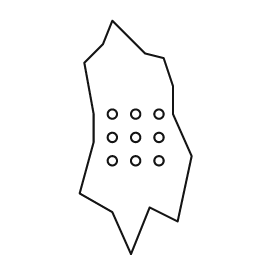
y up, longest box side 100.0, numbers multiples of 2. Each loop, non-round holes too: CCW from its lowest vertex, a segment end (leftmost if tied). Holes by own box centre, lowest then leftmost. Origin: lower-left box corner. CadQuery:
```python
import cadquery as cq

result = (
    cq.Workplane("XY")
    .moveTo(22.0, 0.0)
    .lineTo(30.0, 20.0)
    .lineTo(42.0, 14.0)
    .lineTo(48.0, 42.0)
    .lineTo(40.0, 60.0)
    .lineTo(40.0, 72.0)
    .lineTo(36.0, 84.0)
    .lineTo(28.0, 86.0)
    .lineTo(14.0, 100.0)
    .lineTo(10.0, 90.0)
    .lineTo(2.0, 82.0)
    .lineTo(6.0, 60.0)
    .lineTo(6.0, 48.0)
    .lineTo(0.0, 26.0)
    .lineTo(14.0, 18.0)
    .close()
    .moveTo(14.0, 40.0)
    .circle(2.0)
    .moveTo(24.0, 40.0)
    .circle(2.0)
    .moveTo(34.0, 40.0)
    .circle(2.0)
    .moveTo(14.0, 50.0)
    .circle(2.0)
    .moveTo(24.0, 50.0)
    .circle(2.0)
    .moveTo(34.0, 50.0)
    .circle(2.0)
    .moveTo(14.0, 60.0)
    .circle(2.0)
    .moveTo(24.0, 60.0)
    .circle(2.0)
    .moveTo(34.0, 60.0)
    .circle(2.0)
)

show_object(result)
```